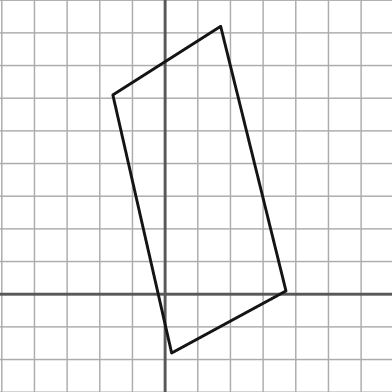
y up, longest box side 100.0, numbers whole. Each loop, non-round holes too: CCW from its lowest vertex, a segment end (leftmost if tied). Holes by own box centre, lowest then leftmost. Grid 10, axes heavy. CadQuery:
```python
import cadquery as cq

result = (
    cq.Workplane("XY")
    .moveTo(2.0, -18.0)
    .lineTo(37.0, 1.0)
    .lineTo(17.0, 82.0)
    .lineTo(-16.0, 61.0)
    .close()
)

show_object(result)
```